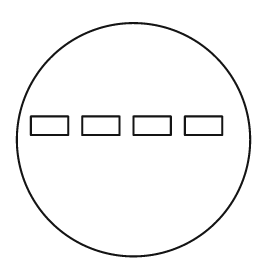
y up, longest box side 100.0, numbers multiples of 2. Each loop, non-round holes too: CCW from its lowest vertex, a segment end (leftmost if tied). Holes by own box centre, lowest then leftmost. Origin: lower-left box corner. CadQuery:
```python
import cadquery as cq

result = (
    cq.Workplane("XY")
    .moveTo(50.0, 50.0)
    .circle(50.0)
    .moveTo(6.0, 52.0)
    .lineTo(22.0, 52.0)
    .lineTo(22.0, 60.0)
    .lineTo(6.0, 60.0)
    .close()
    .moveTo(28.0, 52.0)
    .lineTo(44.0, 52.0)
    .lineTo(44.0, 60.0)
    .lineTo(28.0, 60.0)
    .close()
    .moveTo(50.0, 52.0)
    .lineTo(66.0, 52.0)
    .lineTo(66.0, 60.0)
    .lineTo(50.0, 60.0)
    .close()
    .moveTo(72.0, 52.0)
    .lineTo(88.0, 52.0)
    .lineTo(88.0, 60.0)
    .lineTo(72.0, 60.0)
    .close()
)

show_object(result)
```